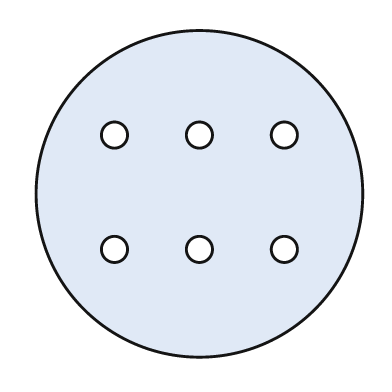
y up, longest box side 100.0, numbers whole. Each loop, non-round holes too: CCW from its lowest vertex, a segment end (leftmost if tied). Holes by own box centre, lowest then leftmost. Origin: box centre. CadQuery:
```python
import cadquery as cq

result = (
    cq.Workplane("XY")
    .moveTo(0.0, 0.0)
    .circle(50.0)
    .moveTo(-26.0, -17.0)
    .circle(4.0)
    .moveTo(0.0, -17.0)
    .circle(4.0)
    .moveTo(26.0, -17.0)
    .circle(4.0)
    .moveTo(-26.0, 18.0)
    .circle(4.0)
    .moveTo(0.0, 18.0)
    .circle(4.0)
    .moveTo(26.0, 18.0)
    .circle(4.0)
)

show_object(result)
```